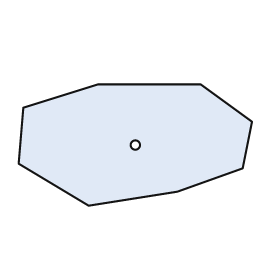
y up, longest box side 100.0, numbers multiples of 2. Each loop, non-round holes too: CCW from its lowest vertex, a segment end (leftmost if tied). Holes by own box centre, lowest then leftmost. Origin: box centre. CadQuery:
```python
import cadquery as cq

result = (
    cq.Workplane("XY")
    .moveTo(-20.0, -26.0)
    .lineTo(18.0, -20.0)
    .lineTo(46.0, -10.0)
    .lineTo(50.0, 10.0)
    .lineTo(28.0, 26.0)
    .lineTo(-16.0, 26.0)
    .lineTo(-48.0, 16.0)
    .lineTo(-50.0, -8.0)
    .close()
    .moveTo(0.0, 0.0)
    .circle(2.0)
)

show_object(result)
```